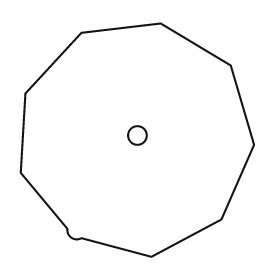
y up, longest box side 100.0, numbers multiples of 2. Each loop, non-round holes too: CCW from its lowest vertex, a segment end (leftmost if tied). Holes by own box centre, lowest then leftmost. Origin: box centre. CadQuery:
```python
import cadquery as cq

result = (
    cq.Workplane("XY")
    .moveTo(6.0, -50.0)
    .lineTo(36.0, -34.0)
    .lineTo(50.0, -2.0)
    .lineTo(40.0, 32.0)
    .lineTo(10.0, 50.0)
    .lineTo(-24.0, 46.0)
    .lineTo(-48.0, 20.0)
    .lineTo(-50.0, -14.0)
    .lineTo(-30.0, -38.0)
    .threePointArc((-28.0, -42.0), (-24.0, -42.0))
    .close()
    .moveTo(0.0, 2.0)
    .circle(4.0)
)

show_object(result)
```